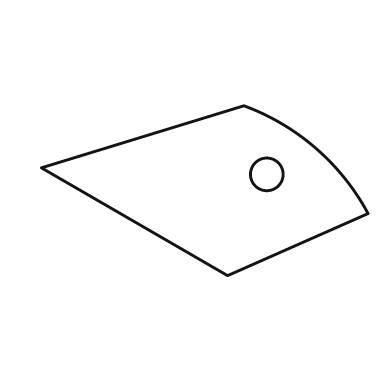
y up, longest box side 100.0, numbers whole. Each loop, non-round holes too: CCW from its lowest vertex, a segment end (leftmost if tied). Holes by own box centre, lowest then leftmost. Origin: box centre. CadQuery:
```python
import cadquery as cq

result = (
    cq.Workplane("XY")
    .moveTo(7.0, -26.0)
    .lineTo(50.0, -7.0)
    .threePointArc((34.0, 13.0), (12.0, 26.0))
    .lineTo(-50.0, 7.0)
    .close()
    .moveTo(19.0, 5.0)
    .circle(5.0)
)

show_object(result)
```